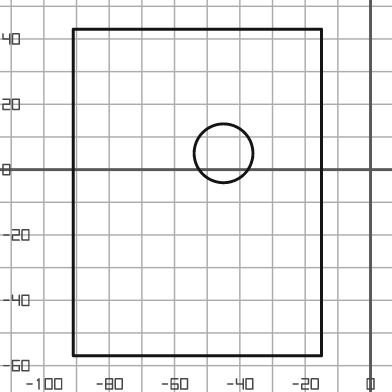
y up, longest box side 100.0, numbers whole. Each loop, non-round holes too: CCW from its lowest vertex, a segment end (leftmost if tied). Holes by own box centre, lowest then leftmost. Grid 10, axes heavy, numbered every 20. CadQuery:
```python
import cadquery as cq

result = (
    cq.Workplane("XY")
    .moveTo(-91.0, -57.0)
    .lineTo(-15.0, -57.0)
    .lineTo(-15.0, 43.0)
    .lineTo(-91.0, 43.0)
    .close()
    .moveTo(-45.0, 5.0)
    .circle(9.0)
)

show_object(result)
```